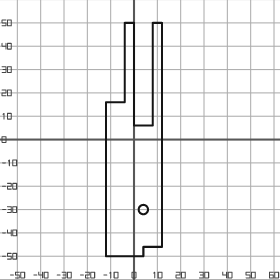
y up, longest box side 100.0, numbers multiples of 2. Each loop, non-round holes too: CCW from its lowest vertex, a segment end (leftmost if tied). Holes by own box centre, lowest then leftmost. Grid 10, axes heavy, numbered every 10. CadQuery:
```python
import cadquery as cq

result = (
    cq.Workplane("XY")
    .moveTo(-12.0, -50.0)
    .lineTo(4.0, -50.0)
    .lineTo(4.0, -46.0)
    .lineTo(12.0, -46.0)
    .lineTo(12.0, 50.0)
    .lineTo(8.0, 50.0)
    .lineTo(8.0, 6.0)
    .lineTo(0.0, 6.0)
    .lineTo(0.0, 50.0)
    .lineTo(-4.0, 50.0)
    .lineTo(-4.0, 16.0)
    .lineTo(-12.0, 16.0)
    .close()
    .moveTo(4.0, -30.0)
    .circle(2.0)
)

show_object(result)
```